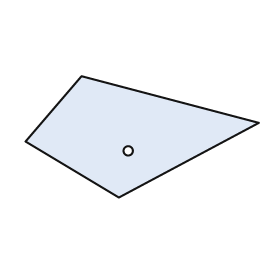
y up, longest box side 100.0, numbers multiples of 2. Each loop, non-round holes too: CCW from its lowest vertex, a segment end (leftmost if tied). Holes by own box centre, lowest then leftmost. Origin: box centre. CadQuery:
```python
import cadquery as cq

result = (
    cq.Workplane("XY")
    .moveTo(-10.0, -26.0)
    .lineTo(50.0, 6.0)
    .lineTo(-26.0, 26.0)
    .lineTo(-50.0, -2.0)
    .close()
    .moveTo(-6.0, -6.0)
    .circle(2.0)
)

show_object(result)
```